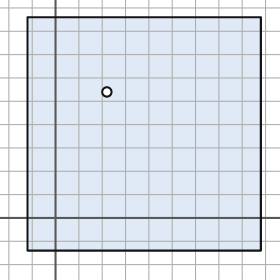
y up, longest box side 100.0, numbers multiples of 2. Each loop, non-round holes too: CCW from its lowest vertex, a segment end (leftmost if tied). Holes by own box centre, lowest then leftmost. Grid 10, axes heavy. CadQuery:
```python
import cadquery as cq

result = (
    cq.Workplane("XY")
    .moveTo(-12.0, -14.0)
    .lineTo(88.0, -14.0)
    .lineTo(88.0, 86.0)
    .lineTo(-12.0, 86.0)
    .close()
    .moveTo(22.0, 54.0)
    .circle(2.0)
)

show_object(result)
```